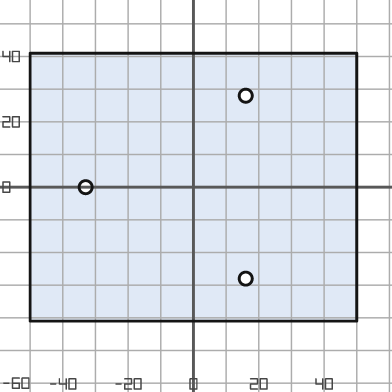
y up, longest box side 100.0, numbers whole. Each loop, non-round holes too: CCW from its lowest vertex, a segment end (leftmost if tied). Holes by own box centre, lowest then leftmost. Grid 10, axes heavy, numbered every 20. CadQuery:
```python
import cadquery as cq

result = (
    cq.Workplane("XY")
    .moveTo(-50.0, -41.0)
    .lineTo(50.0, -41.0)
    .lineTo(50.0, 41.0)
    .lineTo(-50.0, 41.0)
    .close()
    .moveTo(16.0, -28.0)
    .circle(2.0)
    .moveTo(-33.0, 0.0)
    .circle(2.0)
    .moveTo(16.0, 28.0)
    .circle(2.0)
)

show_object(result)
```